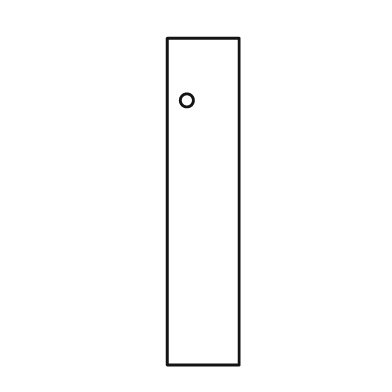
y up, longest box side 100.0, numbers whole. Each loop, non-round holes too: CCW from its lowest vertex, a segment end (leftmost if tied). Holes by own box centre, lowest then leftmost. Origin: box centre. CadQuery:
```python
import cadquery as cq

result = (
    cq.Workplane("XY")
    .moveTo(-11.0, -50.0)
    .lineTo(11.0, -50.0)
    .lineTo(11.0, 50.0)
    .lineTo(-11.0, 50.0)
    .close()
    .moveTo(-5.0, 31.0)
    .circle(2.0)
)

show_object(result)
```